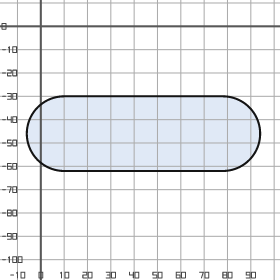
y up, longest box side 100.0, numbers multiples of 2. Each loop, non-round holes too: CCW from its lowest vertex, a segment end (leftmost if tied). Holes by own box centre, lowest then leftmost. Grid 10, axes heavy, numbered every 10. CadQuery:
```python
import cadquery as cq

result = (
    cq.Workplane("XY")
    .moveTo(10.0, -62.0)
    .lineTo(78.0, -62.0)
    .threePointArc((94.0, -46.0), (78.0, -30.0))
    .lineTo(10.0, -30.0)
    .threePointArc((-6.0, -46.0), (10.0, -62.0))
    .close()
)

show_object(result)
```